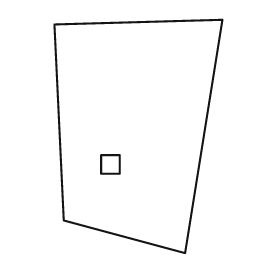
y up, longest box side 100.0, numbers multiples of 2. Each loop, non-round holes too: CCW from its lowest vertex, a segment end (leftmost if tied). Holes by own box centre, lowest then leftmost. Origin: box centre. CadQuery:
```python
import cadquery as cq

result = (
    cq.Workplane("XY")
    .moveTo(20.0, -50.0)
    .lineTo(36.0, 50.0)
    .lineTo(-36.0, 48.0)
    .lineTo(-32.0, -36.0)
    .close()
    .moveTo(-16.0, -16.0)
    .lineTo(-8.0, -16.0)
    .lineTo(-8.0, -8.0)
    .lineTo(-16.0, -8.0)
    .close()
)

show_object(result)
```